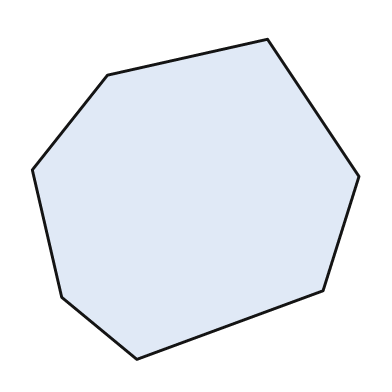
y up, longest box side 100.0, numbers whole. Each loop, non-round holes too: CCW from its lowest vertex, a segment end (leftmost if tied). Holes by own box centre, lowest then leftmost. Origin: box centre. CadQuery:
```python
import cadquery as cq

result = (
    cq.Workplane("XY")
    .moveTo(-18.0, -49.0)
    .lineTo(39.0, -28.0)
    .lineTo(50.0, 7.0)
    .lineTo(22.0, 49.0)
    .lineTo(-27.0, 38.0)
    .lineTo(-50.0, 9.0)
    .lineTo(-41.0, -30.0)
    .close()
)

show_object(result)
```